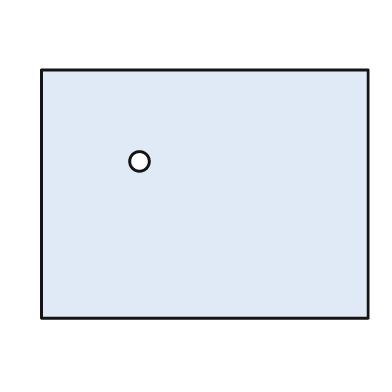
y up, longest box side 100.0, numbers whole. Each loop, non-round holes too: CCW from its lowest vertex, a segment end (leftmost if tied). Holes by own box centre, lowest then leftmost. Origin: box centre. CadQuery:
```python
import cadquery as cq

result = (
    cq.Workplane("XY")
    .moveTo(-50.0, -38.0)
    .lineTo(50.0, -38.0)
    .lineTo(50.0, 38.0)
    .lineTo(-50.0, 38.0)
    .close()
    .moveTo(-20.0, 10.0)
    .circle(3.0)
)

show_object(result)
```